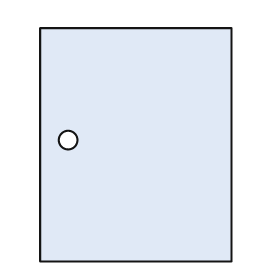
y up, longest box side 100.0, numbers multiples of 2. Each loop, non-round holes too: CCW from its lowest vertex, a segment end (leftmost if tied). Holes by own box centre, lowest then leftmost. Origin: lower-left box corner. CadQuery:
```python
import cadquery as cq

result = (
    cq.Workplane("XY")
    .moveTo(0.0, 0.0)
    .lineTo(82.0, 0.0)
    .lineTo(82.0, 100.0)
    .lineTo(0.0, 100.0)
    .close()
    .moveTo(12.0, 52.0)
    .circle(4.0)
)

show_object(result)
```